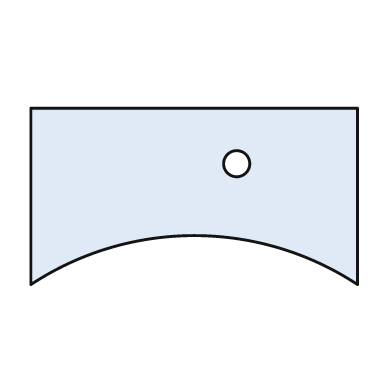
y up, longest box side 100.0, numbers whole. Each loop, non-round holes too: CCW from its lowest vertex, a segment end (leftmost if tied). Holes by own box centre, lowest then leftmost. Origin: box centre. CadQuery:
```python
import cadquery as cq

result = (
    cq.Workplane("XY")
    .moveTo(-50.0, -27.0)
    .threePointArc((0.0, -12.0), (50.0, -27.0))
    .lineTo(50.0, 27.0)
    .lineTo(-50.0, 27.0)
    .close()
    .moveTo(13.0, 10.0)
    .circle(4.0)
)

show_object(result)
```